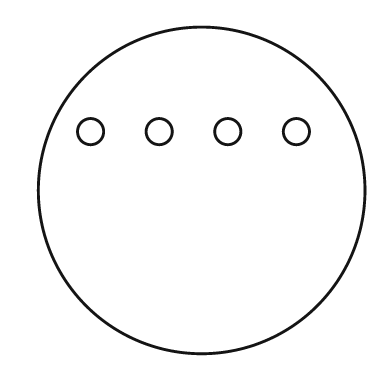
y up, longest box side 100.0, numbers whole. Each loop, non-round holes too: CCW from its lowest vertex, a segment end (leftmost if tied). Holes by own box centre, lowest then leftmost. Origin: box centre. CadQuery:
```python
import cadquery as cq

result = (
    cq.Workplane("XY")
    .moveTo(0.0, 0.0)
    .circle(50.0)
    .moveTo(-34.0, 18.0)
    .circle(4.0)
    .moveTo(-13.0, 18.0)
    .circle(4.0)
    .moveTo(8.0, 18.0)
    .circle(4.0)
    .moveTo(29.0, 18.0)
    .circle(4.0)
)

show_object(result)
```